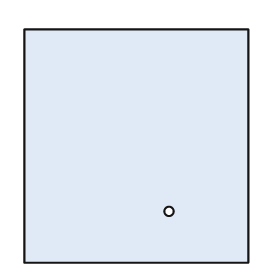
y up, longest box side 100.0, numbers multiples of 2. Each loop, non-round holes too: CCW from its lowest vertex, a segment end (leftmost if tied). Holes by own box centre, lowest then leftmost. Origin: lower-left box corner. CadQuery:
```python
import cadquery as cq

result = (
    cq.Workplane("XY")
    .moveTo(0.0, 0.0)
    .lineTo(96.0, 0.0)
    .lineTo(96.0, 100.0)
    .lineTo(0.0, 100.0)
    .close()
    .moveTo(62.0, 22.0)
    .circle(2.0)
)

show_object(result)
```